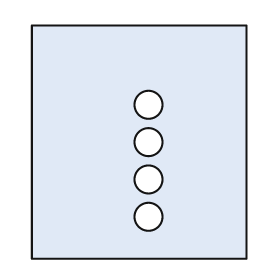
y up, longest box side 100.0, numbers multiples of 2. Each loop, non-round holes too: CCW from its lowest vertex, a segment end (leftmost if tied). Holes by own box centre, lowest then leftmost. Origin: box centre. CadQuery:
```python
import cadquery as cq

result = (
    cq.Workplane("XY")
    .moveTo(-46.0, -50.0)
    .lineTo(46.0, -50.0)
    .lineTo(46.0, 50.0)
    .lineTo(-46.0, 50.0)
    .close()
    .moveTo(4.0, -32.0)
    .circle(6.0)
    .moveTo(4.0, -16.0)
    .circle(6.0)
    .moveTo(4.0, 0.0)
    .circle(6.0)
    .moveTo(4.0, 16.0)
    .circle(6.0)
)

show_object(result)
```